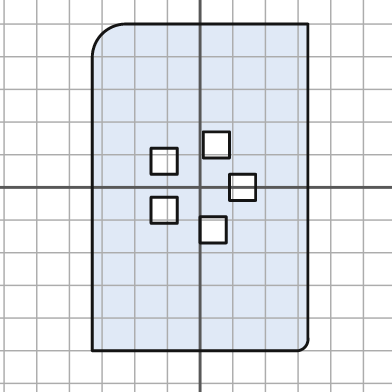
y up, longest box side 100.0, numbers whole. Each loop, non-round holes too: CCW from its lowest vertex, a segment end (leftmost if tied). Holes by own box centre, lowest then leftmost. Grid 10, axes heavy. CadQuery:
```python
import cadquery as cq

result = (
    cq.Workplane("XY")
    .moveTo(-33.0, -50.0)
    .lineTo(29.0, -50.0)
    .threePointArc((32.0, -49.0), (33.0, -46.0))
    .lineTo(33.0, 50.0)
    .lineTo(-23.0, 50.0)
    .threePointArc((-30.0, 47.0), (-33.0, 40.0))
    .close()
    .moveTo(0.0, -17.0)
    .lineTo(8.0, -17.0)
    .lineTo(8.0, -9.0)
    .lineTo(0.0, -9.0)
    .close()
    .moveTo(-15.0, -11.0)
    .lineTo(-7.0, -11.0)
    .lineTo(-7.0, -3.0)
    .lineTo(-15.0, -3.0)
    .close()
    .moveTo(9.0, -4.0)
    .lineTo(17.0, -4.0)
    .lineTo(17.0, 4.0)
    .lineTo(9.0, 4.0)
    .close()
    .moveTo(-15.0, 4.0)
    .lineTo(-7.0, 4.0)
    .lineTo(-7.0, 12.0)
    .lineTo(-15.0, 12.0)
    .close()
    .moveTo(1.0, 9.0)
    .lineTo(9.0, 9.0)
    .lineTo(9.0, 17.0)
    .lineTo(1.0, 17.0)
    .close()
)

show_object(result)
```